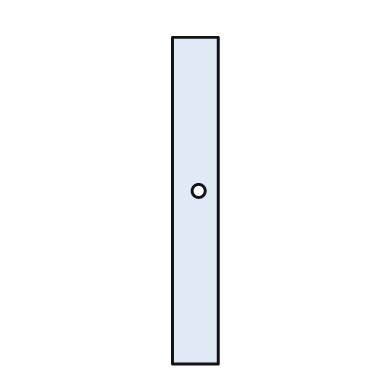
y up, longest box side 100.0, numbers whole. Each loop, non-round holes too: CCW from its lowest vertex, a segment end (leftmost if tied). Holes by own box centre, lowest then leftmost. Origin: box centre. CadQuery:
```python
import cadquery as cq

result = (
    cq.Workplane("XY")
    .moveTo(-7.0, -50.0)
    .lineTo(7.0, -50.0)
    .lineTo(7.0, 50.0)
    .lineTo(-7.0, 50.0)
    .close()
    .moveTo(1.0, 3.0)
    .circle(2.0)
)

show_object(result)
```